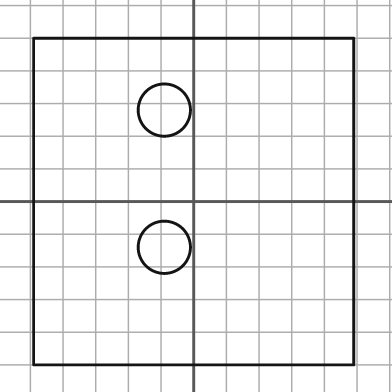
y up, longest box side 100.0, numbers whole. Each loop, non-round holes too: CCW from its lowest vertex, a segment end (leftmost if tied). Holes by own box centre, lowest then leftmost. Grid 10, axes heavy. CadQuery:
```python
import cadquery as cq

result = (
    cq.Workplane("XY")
    .moveTo(-49.0, -50.0)
    .lineTo(49.0, -50.0)
    .lineTo(49.0, 50.0)
    .lineTo(-49.0, 50.0)
    .close()
    .moveTo(-9.0, -14.0)
    .circle(8.0)
    .moveTo(-9.0, 28.0)
    .circle(8.0)
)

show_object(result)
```